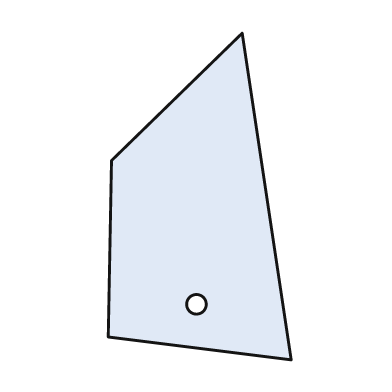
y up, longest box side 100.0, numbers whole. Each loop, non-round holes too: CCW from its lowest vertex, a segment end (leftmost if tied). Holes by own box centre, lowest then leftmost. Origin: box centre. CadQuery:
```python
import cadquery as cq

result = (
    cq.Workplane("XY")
    .moveTo(28.0, -50.0)
    .lineTo(13.0, 50.0)
    .lineTo(-27.0, 11.0)
    .lineTo(-28.0, -43.0)
    .close()
    .moveTo(-1.0, -33.0)
    .circle(3.0)
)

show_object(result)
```